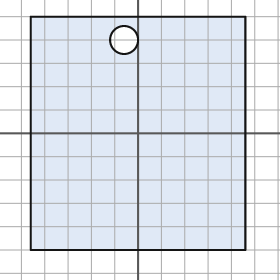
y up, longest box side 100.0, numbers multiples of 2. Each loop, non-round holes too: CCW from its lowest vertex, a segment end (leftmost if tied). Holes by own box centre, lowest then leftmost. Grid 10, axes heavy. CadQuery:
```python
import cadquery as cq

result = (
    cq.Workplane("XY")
    .moveTo(-46.0, -50.0)
    .lineTo(46.0, -50.0)
    .lineTo(46.0, 50.0)
    .lineTo(-46.0, 50.0)
    .close()
    .moveTo(-6.0, 40.0)
    .circle(6.0)
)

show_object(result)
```